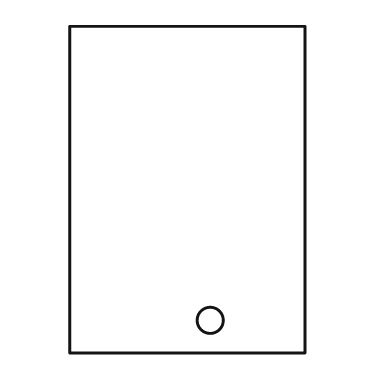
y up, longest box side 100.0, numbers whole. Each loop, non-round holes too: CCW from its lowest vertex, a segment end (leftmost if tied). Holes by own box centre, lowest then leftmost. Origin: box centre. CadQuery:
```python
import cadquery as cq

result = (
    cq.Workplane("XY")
    .moveTo(-36.0, -50.0)
    .lineTo(36.0, -50.0)
    .lineTo(36.0, 50.0)
    .lineTo(-36.0, 50.0)
    .close()
    .moveTo(7.0, -40.0)
    .circle(4.0)
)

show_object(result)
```